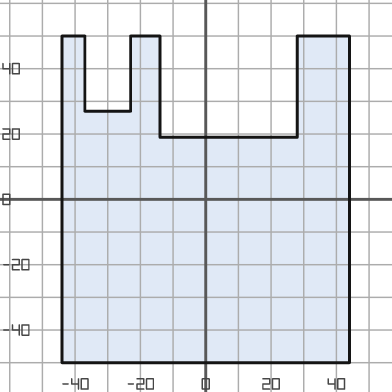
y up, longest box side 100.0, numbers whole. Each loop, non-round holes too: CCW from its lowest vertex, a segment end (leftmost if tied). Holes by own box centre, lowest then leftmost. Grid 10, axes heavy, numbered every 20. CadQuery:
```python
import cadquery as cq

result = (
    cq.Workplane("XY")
    .moveTo(-44.0, -50.0)
    .lineTo(44.0, -50.0)
    .lineTo(44.0, 50.0)
    .lineTo(28.0, 50.0)
    .lineTo(28.0, 19.0)
    .lineTo(-14.0, 19.0)
    .lineTo(-14.0, 50.0)
    .lineTo(-23.0, 50.0)
    .lineTo(-23.0, 27.0)
    .lineTo(-37.0, 27.0)
    .lineTo(-37.0, 50.0)
    .lineTo(-44.0, 50.0)
    .close()
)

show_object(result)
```